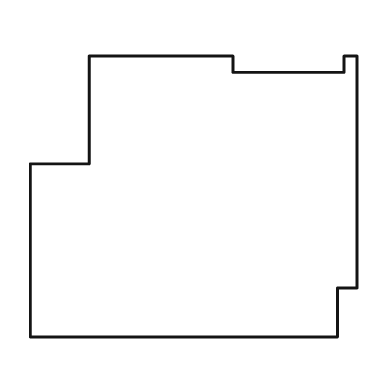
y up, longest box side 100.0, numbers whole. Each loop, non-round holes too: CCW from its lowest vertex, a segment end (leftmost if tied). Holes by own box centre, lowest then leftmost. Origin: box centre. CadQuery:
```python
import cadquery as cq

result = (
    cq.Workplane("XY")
    .moveTo(-50.0, -43.0)
    .lineTo(44.0, -43.0)
    .lineTo(44.0, -28.0)
    .lineTo(50.0, -28.0)
    .lineTo(50.0, 43.0)
    .lineTo(46.0, 43.0)
    .lineTo(46.0, 38.0)
    .lineTo(12.0, 38.0)
    .lineTo(12.0, 43.0)
    .lineTo(-32.0, 43.0)
    .lineTo(-32.0, 10.0)
    .lineTo(-50.0, 10.0)
    .close()
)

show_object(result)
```